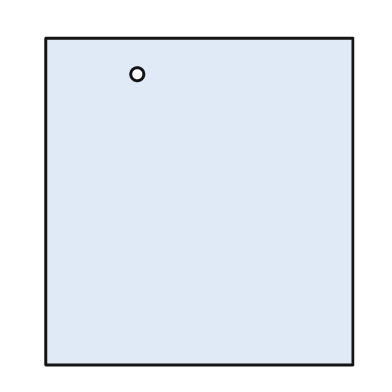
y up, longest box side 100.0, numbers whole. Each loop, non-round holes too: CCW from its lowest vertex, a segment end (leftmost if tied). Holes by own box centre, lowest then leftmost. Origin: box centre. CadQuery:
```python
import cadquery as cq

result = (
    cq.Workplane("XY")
    .moveTo(-47.0, -50.0)
    .lineTo(47.0, -50.0)
    .lineTo(47.0, 50.0)
    .lineTo(-47.0, 50.0)
    .close()
    .moveTo(-19.0, 39.0)
    .circle(2.0)
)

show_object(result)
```